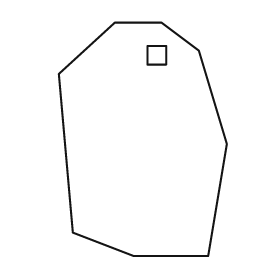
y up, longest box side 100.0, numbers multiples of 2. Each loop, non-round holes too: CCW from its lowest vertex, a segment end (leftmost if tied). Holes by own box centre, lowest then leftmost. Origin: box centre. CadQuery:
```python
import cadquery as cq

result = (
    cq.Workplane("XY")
    .moveTo(-4.0, -50.0)
    .lineTo(28.0, -50.0)
    .lineTo(36.0, -2.0)
    .lineTo(24.0, 38.0)
    .lineTo(8.0, 50.0)
    .lineTo(-12.0, 50.0)
    .lineTo(-36.0, 28.0)
    .lineTo(-30.0, -40.0)
    .close()
    .moveTo(2.0, 32.0)
    .lineTo(10.0, 32.0)
    .lineTo(10.0, 40.0)
    .lineTo(2.0, 40.0)
    .close()
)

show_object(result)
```